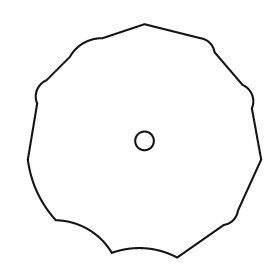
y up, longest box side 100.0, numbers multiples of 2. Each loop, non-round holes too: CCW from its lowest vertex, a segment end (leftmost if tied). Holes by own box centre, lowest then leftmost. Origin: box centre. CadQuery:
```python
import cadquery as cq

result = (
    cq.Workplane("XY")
    .moveTo(14.0, -50.0)
    .lineTo(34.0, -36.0)
    .threePointArc((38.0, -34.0), (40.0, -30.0))
    .lineTo(50.0, -8.0)
    .lineTo(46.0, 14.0)
    .threePointArc((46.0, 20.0), (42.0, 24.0))
    .lineTo(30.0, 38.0)
    .threePointArc((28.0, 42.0), (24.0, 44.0))
    .lineTo(0.0, 50.0)
    .lineTo(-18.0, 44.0)
    .threePointArc((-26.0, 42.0), (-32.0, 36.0))
    .lineTo(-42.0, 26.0)
    .threePointArc((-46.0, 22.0), (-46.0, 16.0))
    .lineTo(-50.0, -8.0)
    .threePointArc((-46.0, -22.0), (-38.0, -34.0))
    .threePointArc((-24.0, -38.0), (-14.0, -48.0))
    .threePointArc((0.0, -46.0), (14.0, -50.0))
    .close()
    .moveTo(0.0, 0.0)
    .circle(4.0)
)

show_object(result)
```